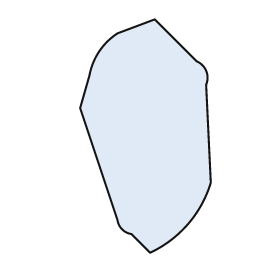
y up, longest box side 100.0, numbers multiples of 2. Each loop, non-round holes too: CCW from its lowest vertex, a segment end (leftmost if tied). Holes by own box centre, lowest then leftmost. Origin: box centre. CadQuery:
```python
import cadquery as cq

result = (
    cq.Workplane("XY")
    .moveTo(2.0, -50.0)
    .threePointArc((18.0, -38.0), (28.0, -20.0))
    .lineTo(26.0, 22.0)
    .threePointArc((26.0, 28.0), (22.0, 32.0))
    .lineTo(4.0, 50.0)
    .lineTo(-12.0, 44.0)
    .threePointArc((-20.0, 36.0), (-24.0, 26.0))
    .lineTo(-28.0, 12.0)
    .lineTo(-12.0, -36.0)
    .threePointArc((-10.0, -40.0), (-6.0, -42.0))
    .close()
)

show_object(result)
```